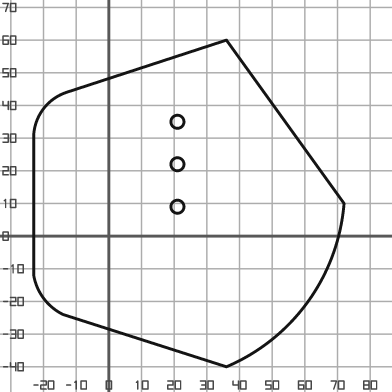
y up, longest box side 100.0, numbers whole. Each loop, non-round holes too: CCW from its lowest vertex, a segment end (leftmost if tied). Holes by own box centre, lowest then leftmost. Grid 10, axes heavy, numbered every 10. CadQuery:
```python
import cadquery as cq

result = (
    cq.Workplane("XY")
    .moveTo(36.0, -40.0)
    .threePointArc((61.0, -20.0), (72.0, 10.0))
    .lineTo(36.0, 60.0)
    .lineTo(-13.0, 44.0)
    .threePointArc((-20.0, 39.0), (-23.0, 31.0))
    .lineTo(-23.0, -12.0)
    .threePointArc((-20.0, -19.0), (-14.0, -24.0))
    .close()
    .moveTo(21.0, 9.0)
    .circle(2.0)
    .moveTo(21.0, 22.0)
    .circle(2.0)
    .moveTo(21.0, 35.0)
    .circle(2.0)
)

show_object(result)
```